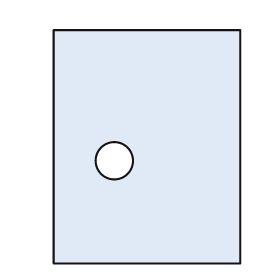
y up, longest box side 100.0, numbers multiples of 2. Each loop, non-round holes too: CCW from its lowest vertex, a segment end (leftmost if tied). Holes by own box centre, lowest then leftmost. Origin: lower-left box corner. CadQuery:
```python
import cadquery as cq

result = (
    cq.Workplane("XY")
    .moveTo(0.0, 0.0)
    .lineTo(80.0, 0.0)
    .lineTo(80.0, 100.0)
    .lineTo(0.0, 100.0)
    .close()
    .moveTo(26.0, 44.0)
    .circle(8.0)
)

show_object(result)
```